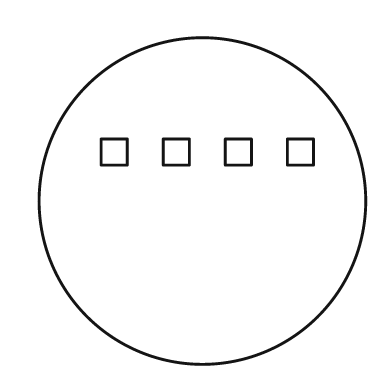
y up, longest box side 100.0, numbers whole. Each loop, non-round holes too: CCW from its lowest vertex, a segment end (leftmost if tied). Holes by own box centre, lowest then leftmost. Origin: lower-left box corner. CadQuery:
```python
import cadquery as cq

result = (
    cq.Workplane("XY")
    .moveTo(50.0, 50.0)
    .circle(50.0)
    .moveTo(19.0, 61.0)
    .lineTo(27.0, 61.0)
    .lineTo(27.0, 69.0)
    .lineTo(19.0, 69.0)
    .close()
    .moveTo(38.0, 61.0)
    .lineTo(46.0, 61.0)
    .lineTo(46.0, 69.0)
    .lineTo(38.0, 69.0)
    .close()
    .moveTo(57.0, 61.0)
    .lineTo(65.0, 61.0)
    .lineTo(65.0, 69.0)
    .lineTo(57.0, 69.0)
    .close()
    .moveTo(76.0, 61.0)
    .lineTo(84.0, 61.0)
    .lineTo(84.0, 69.0)
    .lineTo(76.0, 69.0)
    .close()
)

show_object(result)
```